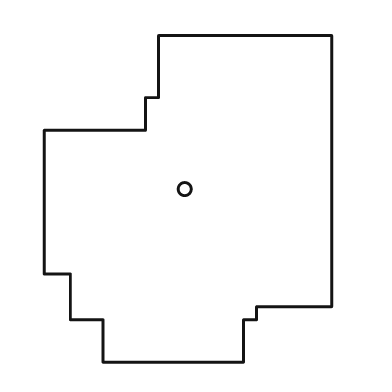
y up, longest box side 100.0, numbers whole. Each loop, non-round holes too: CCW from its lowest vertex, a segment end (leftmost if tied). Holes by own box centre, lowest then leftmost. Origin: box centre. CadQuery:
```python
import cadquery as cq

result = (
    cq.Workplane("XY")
    .moveTo(-26.0, -50.0)
    .lineTo(17.0, -50.0)
    .lineTo(17.0, -37.0)
    .lineTo(21.0, -37.0)
    .lineTo(21.0, -33.0)
    .lineTo(44.0, -33.0)
    .lineTo(44.0, 50.0)
    .lineTo(-9.0, 50.0)
    .lineTo(-9.0, 31.0)
    .lineTo(-13.0, 31.0)
    .lineTo(-13.0, 21.0)
    .lineTo(-44.0, 21.0)
    .lineTo(-44.0, -23.0)
    .lineTo(-36.0, -23.0)
    .lineTo(-36.0, -37.0)
    .lineTo(-26.0, -37.0)
    .close()
    .moveTo(-1.0, 3.0)
    .circle(2.0)
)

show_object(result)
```